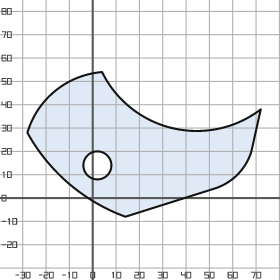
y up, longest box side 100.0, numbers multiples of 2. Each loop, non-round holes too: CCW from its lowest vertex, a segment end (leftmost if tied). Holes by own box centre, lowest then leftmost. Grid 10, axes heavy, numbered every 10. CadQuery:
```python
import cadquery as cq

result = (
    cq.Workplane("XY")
    .moveTo(14.0, -8.0)
    .lineTo(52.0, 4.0)
    .threePointArc((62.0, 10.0), (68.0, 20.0))
    .lineTo(72.0, 38.0)
    .threePointArc((34.0, 30.0), (4.0, 54.0))
    .threePointArc((-16.0, 46.0), (-28.0, 28.0))
    .threePointArc((-10.0, 6.0), (14.0, -8.0))
    .close()
    .moveTo(2.0, 14.0)
    .circle(6.0)
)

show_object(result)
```